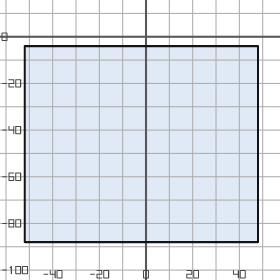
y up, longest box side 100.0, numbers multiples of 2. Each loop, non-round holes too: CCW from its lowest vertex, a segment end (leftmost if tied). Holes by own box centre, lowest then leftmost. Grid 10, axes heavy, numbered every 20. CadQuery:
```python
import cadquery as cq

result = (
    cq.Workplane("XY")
    .moveTo(-52.0, -88.0)
    .lineTo(48.0, -88.0)
    .lineTo(48.0, -4.0)
    .lineTo(-52.0, -4.0)
    .close()
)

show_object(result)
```